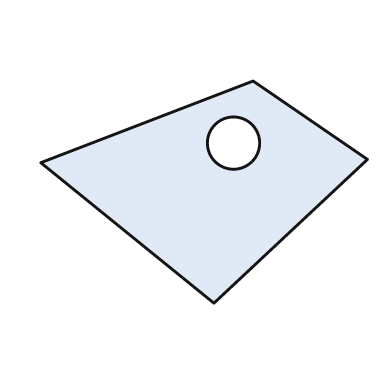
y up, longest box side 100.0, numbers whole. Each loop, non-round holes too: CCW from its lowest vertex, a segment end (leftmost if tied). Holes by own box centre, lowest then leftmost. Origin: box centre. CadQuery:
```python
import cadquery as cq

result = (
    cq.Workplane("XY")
    .moveTo(3.0, -34.0)
    .lineTo(50.0, 10.0)
    .lineTo(15.0, 34.0)
    .lineTo(-50.0, 9.0)
    .close()
    .moveTo(9.0, 15.0)
    .circle(8.0)
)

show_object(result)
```